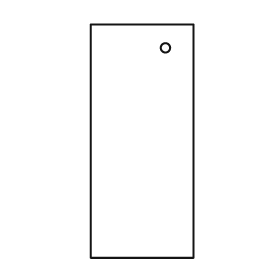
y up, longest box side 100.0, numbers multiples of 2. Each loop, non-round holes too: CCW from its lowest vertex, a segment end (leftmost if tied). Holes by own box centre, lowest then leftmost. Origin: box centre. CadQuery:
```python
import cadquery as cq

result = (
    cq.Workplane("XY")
    .moveTo(-22.0, -50.0)
    .lineTo(22.0, -50.0)
    .lineTo(22.0, 50.0)
    .lineTo(-22.0, 50.0)
    .close()
    .moveTo(10.0, 40.0)
    .circle(2.0)
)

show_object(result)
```